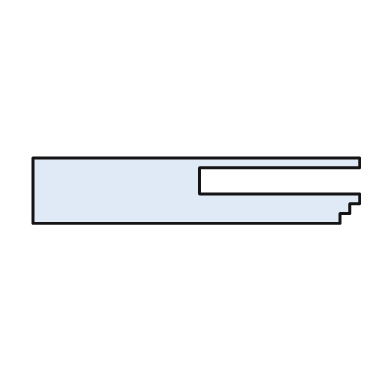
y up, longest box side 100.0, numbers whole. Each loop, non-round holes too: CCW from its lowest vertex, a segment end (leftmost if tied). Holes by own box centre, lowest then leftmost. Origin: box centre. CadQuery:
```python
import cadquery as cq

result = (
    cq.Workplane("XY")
    .moveTo(-50.0, -10.0)
    .lineTo(44.0, -10.0)
    .lineTo(44.0, -7.0)
    .lineTo(47.0, -7.0)
    .lineTo(47.0, -4.0)
    .lineTo(50.0, -4.0)
    .lineTo(50.0, -1.0)
    .lineTo(1.0, -1.0)
    .lineTo(1.0, 7.0)
    .lineTo(50.0, 7.0)
    .lineTo(50.0, 10.0)
    .lineTo(-50.0, 10.0)
    .close()
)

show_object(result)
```